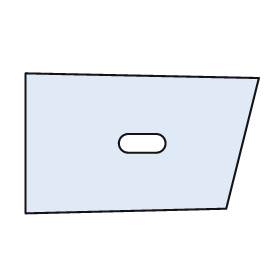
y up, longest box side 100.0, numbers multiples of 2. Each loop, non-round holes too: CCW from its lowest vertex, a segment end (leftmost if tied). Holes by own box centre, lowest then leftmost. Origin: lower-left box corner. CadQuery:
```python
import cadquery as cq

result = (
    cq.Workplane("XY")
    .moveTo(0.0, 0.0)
    .lineTo(86.0, 2.0)
    .lineTo(100.0, 58.0)
    .lineTo(0.0, 60.0)
    .close()
    .moveTo(44.0, 26.0)
    .lineTo(56.0, 26.0)
    .threePointArc((60.0, 30.0), (56.0, 34.0))
    .lineTo(44.0, 34.0)
    .threePointArc((40.0, 30.0), (44.0, 26.0))
    .close()
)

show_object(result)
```